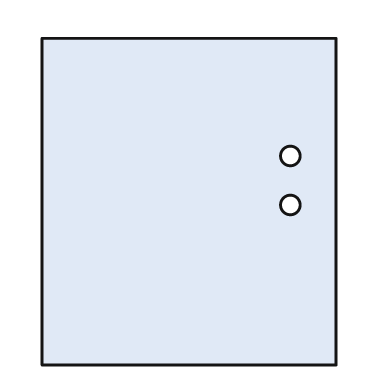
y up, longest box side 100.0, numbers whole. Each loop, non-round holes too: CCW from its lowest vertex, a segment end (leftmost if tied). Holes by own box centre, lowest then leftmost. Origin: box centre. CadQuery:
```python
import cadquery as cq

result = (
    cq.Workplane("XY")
    .moveTo(-45.0, -50.0)
    .lineTo(45.0, -50.0)
    .lineTo(45.0, 50.0)
    .lineTo(-45.0, 50.0)
    .close()
    .moveTo(31.0, -1.0)
    .circle(3.0)
    .moveTo(31.0, 14.0)
    .circle(3.0)
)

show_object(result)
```